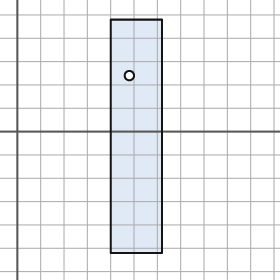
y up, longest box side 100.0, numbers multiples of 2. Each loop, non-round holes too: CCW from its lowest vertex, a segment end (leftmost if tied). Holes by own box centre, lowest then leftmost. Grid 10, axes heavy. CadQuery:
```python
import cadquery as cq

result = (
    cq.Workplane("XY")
    .moveTo(40.0, -52.0)
    .lineTo(62.0, -52.0)
    .lineTo(62.0, 48.0)
    .lineTo(40.0, 48.0)
    .close()
    .moveTo(48.0, 24.0)
    .circle(2.0)
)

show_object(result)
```